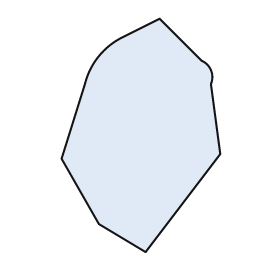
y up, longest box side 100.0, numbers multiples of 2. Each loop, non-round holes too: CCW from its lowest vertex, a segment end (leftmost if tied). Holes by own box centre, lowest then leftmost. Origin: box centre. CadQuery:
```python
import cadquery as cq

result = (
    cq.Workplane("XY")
    .moveTo(2.0, -50.0)
    .lineTo(34.0, -8.0)
    .lineTo(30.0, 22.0)
    .threePointArc((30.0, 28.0), (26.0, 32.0))
    .lineTo(8.0, 50.0)
    .lineTo(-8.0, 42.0)
    .threePointArc((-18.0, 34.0), (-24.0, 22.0))
    .lineTo(-34.0, -10.0)
    .lineTo(-18.0, -38.0)
    .close()
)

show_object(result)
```